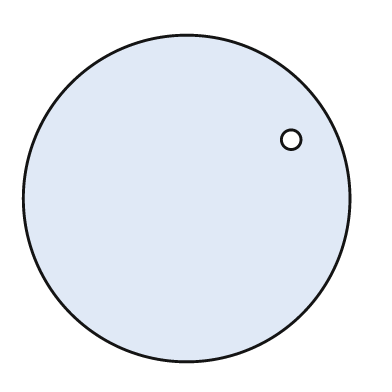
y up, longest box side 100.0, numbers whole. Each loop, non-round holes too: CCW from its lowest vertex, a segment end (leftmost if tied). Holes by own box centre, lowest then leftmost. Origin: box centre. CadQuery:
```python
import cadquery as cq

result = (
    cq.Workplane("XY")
    .moveTo(0.0, 0.0)
    .circle(50.0)
    .moveTo(32.0, 18.0)
    .circle(3.0)
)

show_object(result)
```